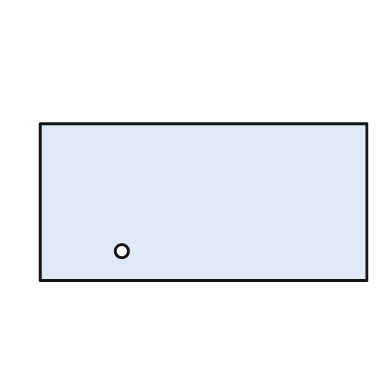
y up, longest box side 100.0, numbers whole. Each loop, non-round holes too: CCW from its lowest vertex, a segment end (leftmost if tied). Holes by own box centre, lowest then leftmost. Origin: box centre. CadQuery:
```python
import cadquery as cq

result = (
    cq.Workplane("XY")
    .moveTo(-50.0, -24.0)
    .lineTo(50.0, -24.0)
    .lineTo(50.0, 24.0)
    .lineTo(-50.0, 24.0)
    .close()
    .moveTo(-25.0, -15.0)
    .circle(2.0)
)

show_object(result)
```